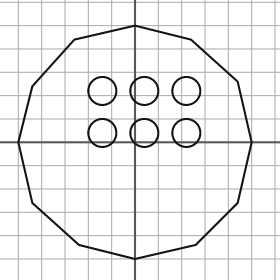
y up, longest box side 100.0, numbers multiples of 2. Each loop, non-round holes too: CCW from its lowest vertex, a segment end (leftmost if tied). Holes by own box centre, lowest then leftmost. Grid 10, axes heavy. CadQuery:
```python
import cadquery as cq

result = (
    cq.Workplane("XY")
    .moveTo(0.0, -50.0)
    .lineTo(26.0, -44.0)
    .lineTo(44.0, -26.0)
    .lineTo(50.0, 0.0)
    .lineTo(44.0, 26.0)
    .lineTo(24.0, 44.0)
    .lineTo(0.0, 50.0)
    .lineTo(-26.0, 44.0)
    .lineTo(-44.0, 24.0)
    .lineTo(-50.0, 0.0)
    .lineTo(-44.0, -26.0)
    .lineTo(-24.0, -44.0)
    .close()
    .moveTo(-14.0, 4.0)
    .circle(6.0)
    .moveTo(4.0, 4.0)
    .circle(6.0)
    .moveTo(22.0, 4.0)
    .circle(6.0)
    .moveTo(-14.0, 22.0)
    .circle(6.0)
    .moveTo(4.0, 22.0)
    .circle(6.0)
    .moveTo(22.0, 22.0)
    .circle(6.0)
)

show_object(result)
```